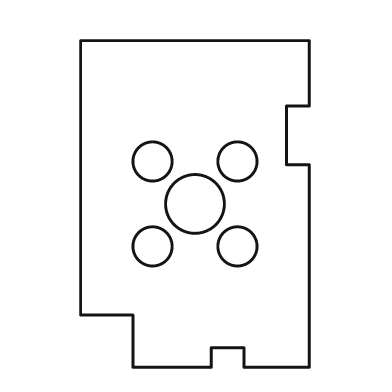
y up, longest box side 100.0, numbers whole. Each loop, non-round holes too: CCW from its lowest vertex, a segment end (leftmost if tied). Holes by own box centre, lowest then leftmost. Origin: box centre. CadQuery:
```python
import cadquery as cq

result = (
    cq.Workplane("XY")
    .moveTo(-19.0, -50.0)
    .lineTo(5.0, -50.0)
    .lineTo(5.0, -44.0)
    .lineTo(15.0, -44.0)
    .lineTo(15.0, -50.0)
    .lineTo(35.0, -50.0)
    .lineTo(35.0, 12.0)
    .lineTo(28.0, 12.0)
    .lineTo(28.0, 30.0)
    .lineTo(35.0, 30.0)
    .lineTo(35.0, 50.0)
    .lineTo(-35.0, 50.0)
    .lineTo(-35.0, -34.0)
    .lineTo(-19.0, -34.0)
    .close()
    .moveTo(-13.0, -13.0)
    .circle(6.0)
    .moveTo(13.0, -13.0)
    .circle(6.0)
    .moveTo(0.0, 0.0)
    .circle(9.0)
    .moveTo(-13.0, 13.0)
    .circle(6.0)
    .moveTo(13.0, 13.0)
    .circle(6.0)
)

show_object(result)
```